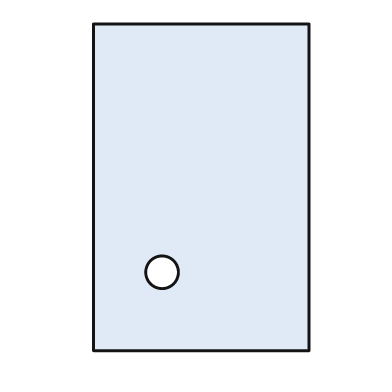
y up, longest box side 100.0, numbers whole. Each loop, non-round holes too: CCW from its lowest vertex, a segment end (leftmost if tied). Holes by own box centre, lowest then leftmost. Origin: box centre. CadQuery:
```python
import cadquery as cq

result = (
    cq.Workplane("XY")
    .moveTo(-33.0, -50.0)
    .lineTo(33.0, -50.0)
    .lineTo(33.0, 50.0)
    .lineTo(-33.0, 50.0)
    .close()
    .moveTo(-12.0, -26.0)
    .circle(5.0)
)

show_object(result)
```